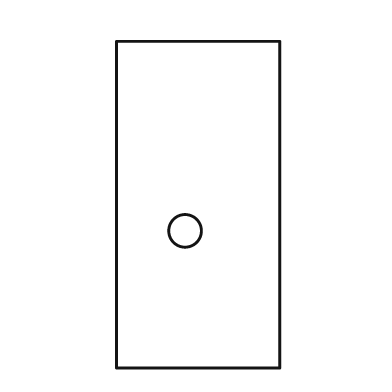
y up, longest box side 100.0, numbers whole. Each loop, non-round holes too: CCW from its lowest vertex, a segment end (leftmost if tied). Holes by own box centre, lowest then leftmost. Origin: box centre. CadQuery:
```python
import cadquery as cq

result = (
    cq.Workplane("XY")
    .moveTo(-25.0, -50.0)
    .lineTo(25.0, -50.0)
    .lineTo(25.0, 50.0)
    .lineTo(-25.0, 50.0)
    .close()
    .moveTo(-4.0, -8.0)
    .circle(5.0)
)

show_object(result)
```